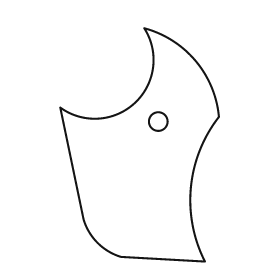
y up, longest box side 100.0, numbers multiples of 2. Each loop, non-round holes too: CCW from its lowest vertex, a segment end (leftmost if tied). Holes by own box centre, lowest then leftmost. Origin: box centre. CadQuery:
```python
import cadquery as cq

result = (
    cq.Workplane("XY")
    .moveTo(28.0, -50.0)
    .threePointArc((22.0, -18.0), (34.0, 12.0))
    .threePointArc((24.0, 36.0), (2.0, 50.0))
    .threePointArc((-2.0, 18.0), (-34.0, 16.0))
    .lineTo(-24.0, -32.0)
    .threePointArc((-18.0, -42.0), (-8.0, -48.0))
    .close()
    .moveTo(8.0, 10.0)
    .circle(4.0)
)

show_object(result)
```